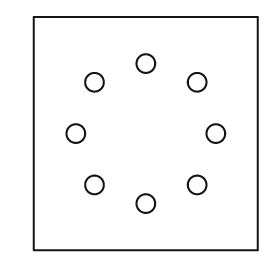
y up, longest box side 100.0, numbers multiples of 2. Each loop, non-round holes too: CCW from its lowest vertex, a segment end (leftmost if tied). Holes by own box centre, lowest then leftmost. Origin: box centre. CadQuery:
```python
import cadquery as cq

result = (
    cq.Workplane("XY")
    .moveTo(-48.0, -50.0)
    .lineTo(48.0, -50.0)
    .lineTo(48.0, 50.0)
    .lineTo(-48.0, 50.0)
    .close()
    .moveTo(0.0, -30.0)
    .circle(4.0)
    .moveTo(-22.0, -22.0)
    .circle(4.0)
    .moveTo(22.0, -22.0)
    .circle(4.0)
    .moveTo(-30.0, 0.0)
    .circle(4.0)
    .moveTo(30.0, 0.0)
    .circle(4.0)
    .moveTo(-22.0, 22.0)
    .circle(4.0)
    .moveTo(22.0, 22.0)
    .circle(4.0)
    .moveTo(0.0, 30.0)
    .circle(4.0)
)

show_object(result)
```